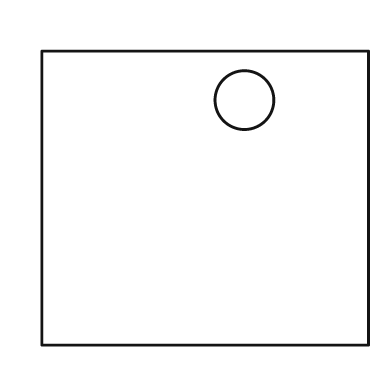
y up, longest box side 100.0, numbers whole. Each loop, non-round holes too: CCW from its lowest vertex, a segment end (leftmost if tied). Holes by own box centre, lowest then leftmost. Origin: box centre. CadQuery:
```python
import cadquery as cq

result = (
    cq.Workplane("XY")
    .moveTo(-50.0, -45.0)
    .lineTo(50.0, -45.0)
    .lineTo(50.0, 45.0)
    .lineTo(-50.0, 45.0)
    .close()
    .moveTo(12.0, 30.0)
    .circle(9.0)
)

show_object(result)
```